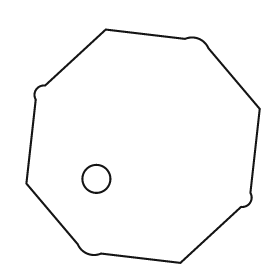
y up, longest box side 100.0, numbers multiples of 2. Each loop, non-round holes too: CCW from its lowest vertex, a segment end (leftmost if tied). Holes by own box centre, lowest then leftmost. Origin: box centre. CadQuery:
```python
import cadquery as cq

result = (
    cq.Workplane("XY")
    .moveTo(16.0, -50.0)
    .lineTo(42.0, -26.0)
    .threePointArc((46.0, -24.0), (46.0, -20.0))
    .lineTo(50.0, 16.0)
    .lineTo(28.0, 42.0)
    .threePointArc((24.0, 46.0), (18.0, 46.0))
    .lineTo(-16.0, 50.0)
    .lineTo(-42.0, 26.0)
    .threePointArc((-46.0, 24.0), (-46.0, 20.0))
    .lineTo(-50.0, -16.0)
    .lineTo(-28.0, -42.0)
    .threePointArc((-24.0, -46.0), (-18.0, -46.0))
    .close()
    .moveTo(-20.0, -14.0)
    .circle(6.0)
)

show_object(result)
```